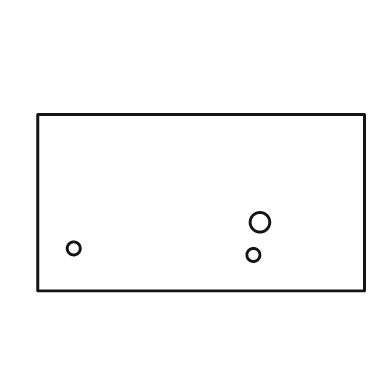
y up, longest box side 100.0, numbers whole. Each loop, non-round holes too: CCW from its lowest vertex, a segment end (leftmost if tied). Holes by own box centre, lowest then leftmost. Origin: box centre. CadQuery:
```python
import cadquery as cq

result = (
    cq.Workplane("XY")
    .moveTo(-50.0, -27.0)
    .lineTo(50.0, -27.0)
    .lineTo(50.0, 27.0)
    .lineTo(-50.0, 27.0)
    .close()
    .moveTo(16.0, -16.0)
    .circle(2.0)
    .moveTo(-39.0, -14.0)
    .circle(2.0)
    .moveTo(18.0, -6.0)
    .circle(3.0)
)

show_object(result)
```